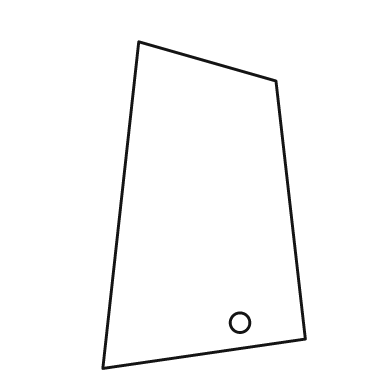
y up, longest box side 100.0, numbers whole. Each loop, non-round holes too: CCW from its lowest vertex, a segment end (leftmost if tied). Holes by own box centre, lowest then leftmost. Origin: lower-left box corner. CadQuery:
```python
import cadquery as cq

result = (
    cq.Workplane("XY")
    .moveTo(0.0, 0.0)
    .lineTo(62.0, 9.0)
    .lineTo(53.0, 88.0)
    .lineTo(11.0, 100.0)
    .close()
    .moveTo(42.0, 14.0)
    .circle(3.0)
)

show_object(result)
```